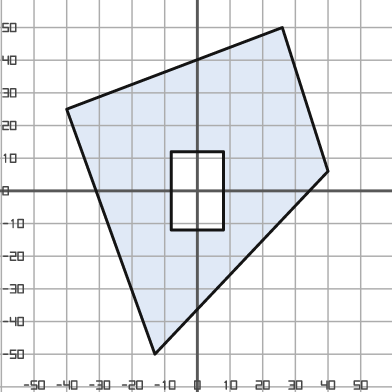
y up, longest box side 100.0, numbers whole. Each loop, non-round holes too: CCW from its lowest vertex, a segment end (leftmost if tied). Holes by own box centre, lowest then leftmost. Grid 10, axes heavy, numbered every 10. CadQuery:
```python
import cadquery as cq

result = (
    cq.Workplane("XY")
    .moveTo(-13.0, -50.0)
    .lineTo(40.0, 6.0)
    .lineTo(26.0, 50.0)
    .lineTo(-40.0, 25.0)
    .close()
    .moveTo(-8.0, -12.0)
    .lineTo(8.0, -12.0)
    .lineTo(8.0, 12.0)
    .lineTo(-8.0, 12.0)
    .close()
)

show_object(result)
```